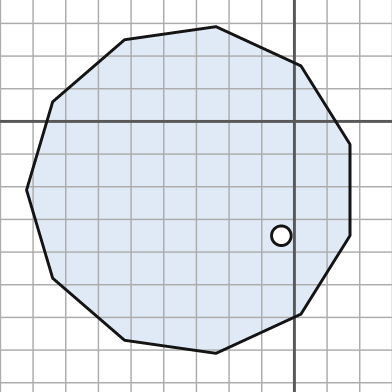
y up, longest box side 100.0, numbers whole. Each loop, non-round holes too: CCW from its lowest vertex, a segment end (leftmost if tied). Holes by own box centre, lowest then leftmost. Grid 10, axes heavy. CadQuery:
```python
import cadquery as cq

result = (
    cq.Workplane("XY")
    .moveTo(-24.0, -71.0)
    .lineTo(2.0, -59.0)
    .lineTo(17.0, -35.0)
    .lineTo(17.0, -7.0)
    .lineTo(2.0, 17.0)
    .lineTo(-24.0, 29.0)
    .lineTo(-52.0, 25.0)
    .lineTo(-74.0, 6.0)
    .lineTo(-82.0, -21.0)
    .lineTo(-74.0, -48.0)
    .lineTo(-52.0, -67.0)
    .close()
    .moveTo(-4.0, -35.0)
    .circle(3.0)
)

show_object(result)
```